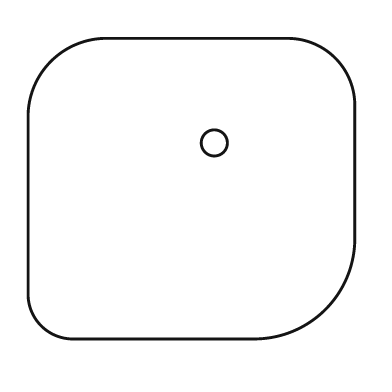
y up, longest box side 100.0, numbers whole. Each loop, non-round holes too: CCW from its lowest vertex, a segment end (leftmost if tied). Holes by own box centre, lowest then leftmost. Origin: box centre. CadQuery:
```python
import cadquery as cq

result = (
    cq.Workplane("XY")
    .moveTo(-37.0, -46.0)
    .lineTo(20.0, -46.0)
    .threePointArc((41.0, -37.0), (50.0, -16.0))
    .lineTo(50.0, 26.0)
    .threePointArc((44.0, 40.0), (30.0, 46.0))
    .lineTo(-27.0, 46.0)
    .threePointArc((-43.0, 39.0), (-50.0, 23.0))
    .lineTo(-50.0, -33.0)
    .threePointArc((-46.0, -42.0), (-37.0, -46.0))
    .close()
    .moveTo(7.0, 14.0)
    .circle(4.0)
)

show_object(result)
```